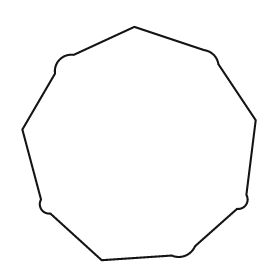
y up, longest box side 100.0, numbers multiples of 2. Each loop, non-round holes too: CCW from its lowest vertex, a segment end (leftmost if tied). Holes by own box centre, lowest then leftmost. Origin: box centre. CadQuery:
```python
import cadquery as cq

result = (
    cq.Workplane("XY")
    .moveTo(-16.0, -50.0)
    .lineTo(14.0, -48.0)
    .threePointArc((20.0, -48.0), (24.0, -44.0))
    .lineTo(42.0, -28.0)
    .threePointArc((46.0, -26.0), (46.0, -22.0))
    .lineTo(50.0, 10.0)
    .lineTo(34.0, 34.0)
    .threePointArc((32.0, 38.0), (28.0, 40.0))
    .lineTo(-2.0, 50.0)
    .lineTo(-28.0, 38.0)
    .threePointArc((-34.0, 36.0), (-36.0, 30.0))
    .lineTo(-50.0, 6.0)
    .lineTo(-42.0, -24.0)
    .threePointArc((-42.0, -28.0), (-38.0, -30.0))
    .close()
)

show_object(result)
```